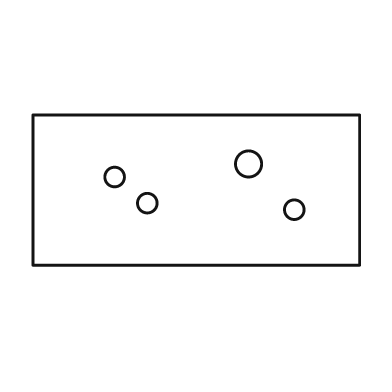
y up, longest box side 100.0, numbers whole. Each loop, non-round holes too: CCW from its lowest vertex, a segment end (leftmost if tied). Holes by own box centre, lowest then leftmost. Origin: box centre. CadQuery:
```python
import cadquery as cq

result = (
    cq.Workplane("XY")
    .moveTo(-50.0, -23.0)
    .lineTo(50.0, -23.0)
    .lineTo(50.0, 23.0)
    .lineTo(-50.0, 23.0)
    .close()
    .moveTo(30.0, -6.0)
    .circle(3.0)
    .moveTo(-15.0, -4.0)
    .circle(3.0)
    .moveTo(-25.0, 4.0)
    .circle(3.0)
    .moveTo(16.0, 8.0)
    .circle(4.0)
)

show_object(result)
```